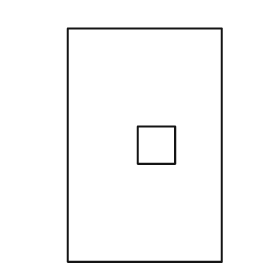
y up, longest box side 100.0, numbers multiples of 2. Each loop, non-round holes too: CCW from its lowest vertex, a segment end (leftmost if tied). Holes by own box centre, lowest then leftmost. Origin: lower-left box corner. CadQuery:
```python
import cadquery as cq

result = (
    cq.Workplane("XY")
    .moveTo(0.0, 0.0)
    .lineTo(66.0, 0.0)
    .lineTo(66.0, 100.0)
    .lineTo(0.0, 100.0)
    .close()
    .moveTo(30.0, 42.0)
    .lineTo(46.0, 42.0)
    .lineTo(46.0, 58.0)
    .lineTo(30.0, 58.0)
    .close()
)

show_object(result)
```